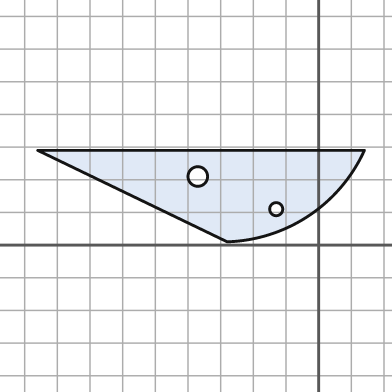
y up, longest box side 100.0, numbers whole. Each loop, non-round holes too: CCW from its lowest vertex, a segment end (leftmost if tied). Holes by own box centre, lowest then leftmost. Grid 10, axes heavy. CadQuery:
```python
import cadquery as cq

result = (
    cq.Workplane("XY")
    .moveTo(-28.0, 1.0)
    .threePointArc((-3.0, 9.0), (14.0, 29.0))
    .lineTo(-86.0, 29.0)
    .close()
    .moveTo(-13.0, 11.0)
    .circle(2.0)
    .moveTo(-37.0, 21.0)
    .circle(3.0)
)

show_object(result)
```